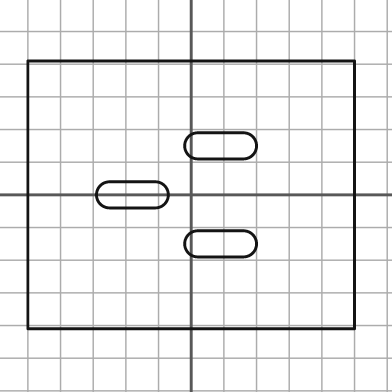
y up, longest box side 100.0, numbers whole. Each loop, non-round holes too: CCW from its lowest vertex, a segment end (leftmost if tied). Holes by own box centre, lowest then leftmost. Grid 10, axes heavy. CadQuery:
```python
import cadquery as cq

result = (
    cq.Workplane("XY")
    .moveTo(-50.0, -41.0)
    .lineTo(50.0, -41.0)
    .lineTo(50.0, 41.0)
    .lineTo(-50.0, 41.0)
    .close()
    .moveTo(2.0, -19.0)
    .lineTo(16.0, -19.0)
    .threePointArc((20.0, -15.0), (16.0, -11.0))
    .lineTo(2.0, -11.0)
    .threePointArc((-2.0, -15.0), (2.0, -19.0))
    .close()
    .moveTo(-25.0, -4.0)
    .lineTo(-11.0, -4.0)
    .threePointArc((-7.0, 0.0), (-11.0, 4.0))
    .lineTo(-25.0, 4.0)
    .threePointArc((-29.0, 0.0), (-25.0, -4.0))
    .close()
    .moveTo(2.0, 11.0)
    .lineTo(16.0, 11.0)
    .threePointArc((20.0, 15.0), (16.0, 19.0))
    .lineTo(2.0, 19.0)
    .threePointArc((-2.0, 15.0), (2.0, 11.0))
    .close()
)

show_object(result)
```